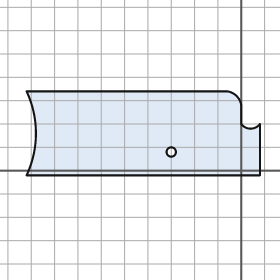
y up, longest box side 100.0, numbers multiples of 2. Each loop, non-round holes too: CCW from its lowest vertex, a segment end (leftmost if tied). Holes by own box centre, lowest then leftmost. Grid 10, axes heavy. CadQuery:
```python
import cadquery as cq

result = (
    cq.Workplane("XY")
    .moveTo(-92.0, -2.0)
    .lineTo(8.0, -2.0)
    .lineTo(8.0, 20.0)
    .threePointArc((4.0, 18.0), (0.0, 20.0))
    .lineTo(0.0, 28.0)
    .threePointArc((-2.0, 32.0), (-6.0, 34.0))
    .lineTo(-92.0, 34.0)
    .threePointArc((-88.0, 16.0), (-92.0, -2.0))
    .close()
    .moveTo(-30.0, 8.0)
    .circle(2.0)
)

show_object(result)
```